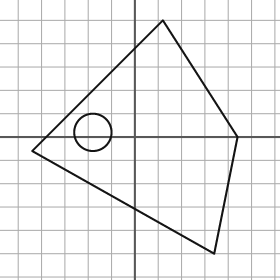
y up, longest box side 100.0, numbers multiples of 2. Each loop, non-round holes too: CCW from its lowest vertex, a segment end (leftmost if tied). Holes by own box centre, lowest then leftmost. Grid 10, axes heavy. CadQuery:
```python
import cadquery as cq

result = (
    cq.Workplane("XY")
    .moveTo(34.0, -50.0)
    .lineTo(44.0, 0.0)
    .lineTo(12.0, 50.0)
    .lineTo(-44.0, -6.0)
    .close()
    .moveTo(-18.0, 2.0)
    .circle(8.0)
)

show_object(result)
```